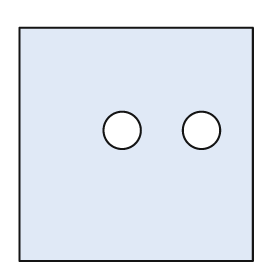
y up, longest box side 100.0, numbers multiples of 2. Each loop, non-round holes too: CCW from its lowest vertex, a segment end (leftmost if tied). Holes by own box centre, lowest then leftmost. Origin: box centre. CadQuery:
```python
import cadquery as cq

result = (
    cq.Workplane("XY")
    .moveTo(-50.0, -50.0)
    .lineTo(50.0, -50.0)
    .lineTo(50.0, 50.0)
    .lineTo(-50.0, 50.0)
    .close()
    .moveTo(-6.0, 6.0)
    .circle(8.0)
    .moveTo(28.0, 6.0)
    .circle(8.0)
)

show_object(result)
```